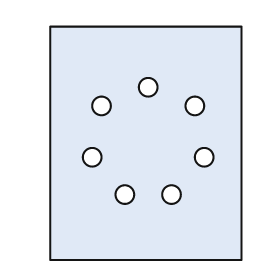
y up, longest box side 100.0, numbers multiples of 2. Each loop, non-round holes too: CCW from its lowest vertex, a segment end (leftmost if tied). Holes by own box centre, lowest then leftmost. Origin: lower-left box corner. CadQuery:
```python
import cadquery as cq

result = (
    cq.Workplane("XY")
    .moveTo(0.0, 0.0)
    .lineTo(82.0, 0.0)
    .lineTo(82.0, 100.0)
    .lineTo(0.0, 100.0)
    .close()
    .moveTo(32.0, 28.0)
    .circle(4.0)
    .moveTo(52.0, 28.0)
    .circle(4.0)
    .moveTo(18.0, 44.0)
    .circle(4.0)
    .moveTo(66.0, 44.0)
    .circle(4.0)
    .moveTo(22.0, 66.0)
    .circle(4.0)
    .moveTo(62.0, 66.0)
    .circle(4.0)
    .moveTo(42.0, 74.0)
    .circle(4.0)
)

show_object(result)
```